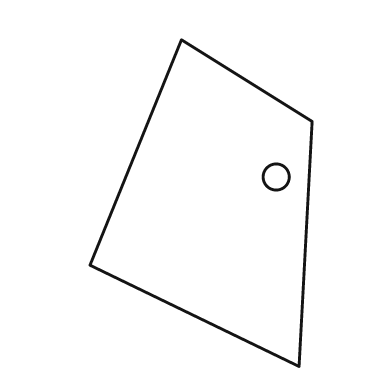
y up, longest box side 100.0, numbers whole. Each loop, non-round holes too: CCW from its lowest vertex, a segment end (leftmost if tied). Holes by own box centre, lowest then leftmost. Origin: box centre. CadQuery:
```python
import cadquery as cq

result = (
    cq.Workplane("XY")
    .moveTo(30.0, -50.0)
    .lineTo(34.0, 25.0)
    .lineTo(-6.0, 50.0)
    .lineTo(-34.0, -19.0)
    .close()
    .moveTo(23.0, 8.0)
    .circle(4.0)
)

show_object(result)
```